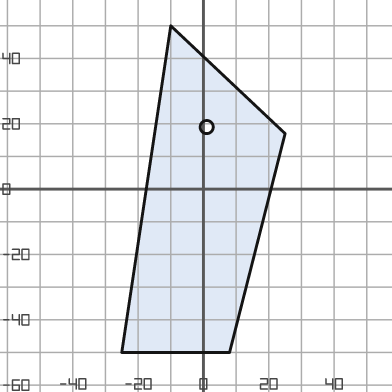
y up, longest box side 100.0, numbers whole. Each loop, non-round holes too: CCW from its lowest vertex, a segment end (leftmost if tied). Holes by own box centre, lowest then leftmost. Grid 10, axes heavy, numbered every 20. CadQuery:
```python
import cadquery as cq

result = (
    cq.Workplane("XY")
    .moveTo(-25.0, -50.0)
    .lineTo(8.0, -50.0)
    .lineTo(25.0, 17.0)
    .lineTo(-10.0, 50.0)
    .close()
    .moveTo(1.0, 19.0)
    .circle(2.0)
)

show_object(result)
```